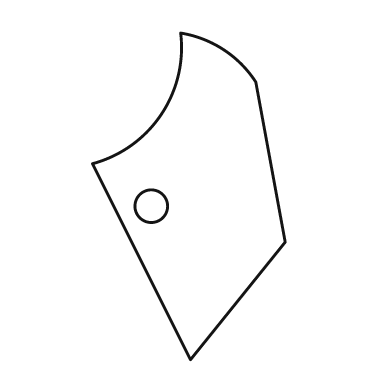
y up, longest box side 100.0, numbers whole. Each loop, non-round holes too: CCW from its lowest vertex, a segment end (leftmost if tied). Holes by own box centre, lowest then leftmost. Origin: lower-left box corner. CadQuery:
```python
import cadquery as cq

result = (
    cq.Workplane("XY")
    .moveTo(30.0, 0.0)
    .lineTo(59.0, 36.0)
    .lineTo(50.0, 85.0)
    .threePointArc((40.0, 95.0), (27.0, 100.0))
    .threePointArc((21.0, 75.0), (0.0, 60.0))
    .close()
    .moveTo(18.0, 47.0)
    .circle(5.0)
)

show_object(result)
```